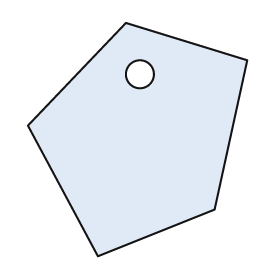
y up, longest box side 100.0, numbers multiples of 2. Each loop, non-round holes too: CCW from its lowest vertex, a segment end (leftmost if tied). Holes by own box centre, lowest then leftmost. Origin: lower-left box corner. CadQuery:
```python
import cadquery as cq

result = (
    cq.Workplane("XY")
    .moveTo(30.0, 0.0)
    .lineTo(80.0, 20.0)
    .lineTo(94.0, 84.0)
    .lineTo(42.0, 100.0)
    .lineTo(0.0, 56.0)
    .close()
    .moveTo(48.0, 78.0)
    .circle(6.0)
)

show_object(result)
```